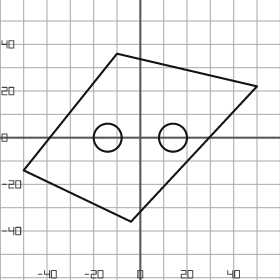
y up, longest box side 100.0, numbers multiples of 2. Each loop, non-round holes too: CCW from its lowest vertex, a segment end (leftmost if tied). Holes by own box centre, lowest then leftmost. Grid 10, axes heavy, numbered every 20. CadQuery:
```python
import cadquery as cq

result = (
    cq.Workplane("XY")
    .moveTo(-4.0, -36.0)
    .lineTo(50.0, 22.0)
    .lineTo(-10.0, 36.0)
    .lineTo(-50.0, -14.0)
    .close()
    .moveTo(-14.0, 0.0)
    .circle(6.0)
    .moveTo(14.0, 0.0)
    .circle(6.0)
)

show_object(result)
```